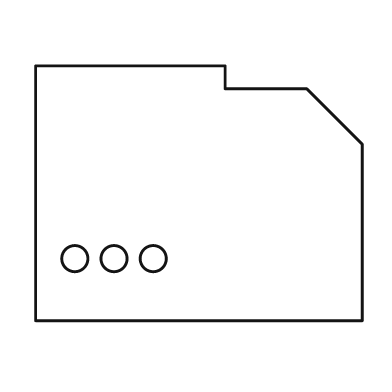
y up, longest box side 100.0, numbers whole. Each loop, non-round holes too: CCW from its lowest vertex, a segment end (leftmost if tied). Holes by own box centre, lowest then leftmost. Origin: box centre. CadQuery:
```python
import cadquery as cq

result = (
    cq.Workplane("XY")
    .moveTo(-50.0, -39.0)
    .lineTo(50.0, -39.0)
    .lineTo(50.0, 15.0)
    .lineTo(33.0, 32.0)
    .lineTo(8.0, 32.0)
    .lineTo(8.0, 39.0)
    .lineTo(-50.0, 39.0)
    .close()
    .moveTo(-38.0, -20.0)
    .circle(4.0)
    .moveTo(-26.0, -20.0)
    .circle(4.0)
    .moveTo(-14.0, -20.0)
    .circle(4.0)
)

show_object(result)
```